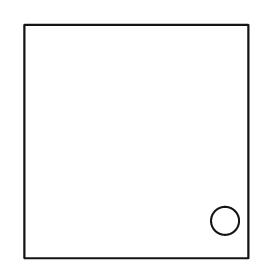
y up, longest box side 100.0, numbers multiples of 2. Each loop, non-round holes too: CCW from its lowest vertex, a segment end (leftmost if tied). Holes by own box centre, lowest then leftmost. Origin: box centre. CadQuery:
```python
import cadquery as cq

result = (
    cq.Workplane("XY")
    .moveTo(-48.0, -50.0)
    .lineTo(48.0, -50.0)
    .lineTo(48.0, 50.0)
    .lineTo(-48.0, 50.0)
    .close()
    .moveTo(38.0, -34.0)
    .circle(6.0)
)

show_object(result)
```